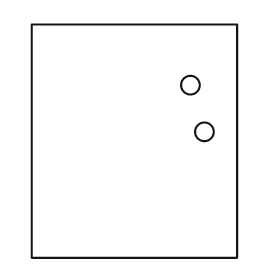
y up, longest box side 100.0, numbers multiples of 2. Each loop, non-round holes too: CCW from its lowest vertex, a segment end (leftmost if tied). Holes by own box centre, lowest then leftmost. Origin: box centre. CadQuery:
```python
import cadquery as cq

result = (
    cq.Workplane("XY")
    .moveTo(-44.0, -50.0)
    .lineTo(44.0, -50.0)
    .lineTo(44.0, 50.0)
    .lineTo(-44.0, 50.0)
    .close()
    .moveTo(30.0, 4.0)
    .circle(4.0)
    .moveTo(24.0, 24.0)
    .circle(4.0)
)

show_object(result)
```